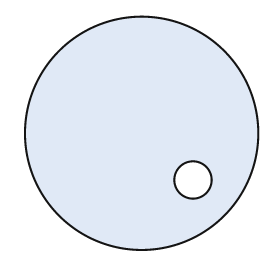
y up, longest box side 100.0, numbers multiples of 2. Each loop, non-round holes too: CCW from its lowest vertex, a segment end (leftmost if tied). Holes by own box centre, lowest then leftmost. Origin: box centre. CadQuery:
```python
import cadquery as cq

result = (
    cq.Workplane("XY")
    .moveTo(0.0, 0.0)
    .circle(50.0)
    .moveTo(22.0, -20.0)
    .circle(8.0)
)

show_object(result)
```